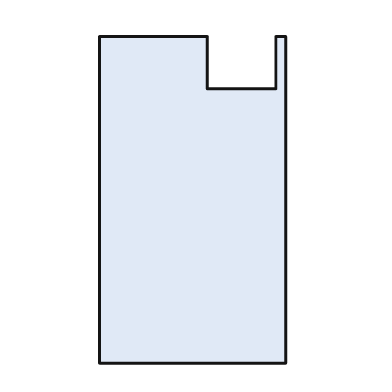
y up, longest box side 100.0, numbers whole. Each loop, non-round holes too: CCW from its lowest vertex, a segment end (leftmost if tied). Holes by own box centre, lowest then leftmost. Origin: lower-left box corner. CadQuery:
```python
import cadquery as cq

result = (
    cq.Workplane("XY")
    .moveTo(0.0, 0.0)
    .lineTo(57.0, 0.0)
    .lineTo(57.0, 100.0)
    .lineTo(54.0, 100.0)
    .lineTo(54.0, 84.0)
    .lineTo(33.0, 84.0)
    .lineTo(33.0, 100.0)
    .lineTo(0.0, 100.0)
    .close()
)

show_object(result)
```